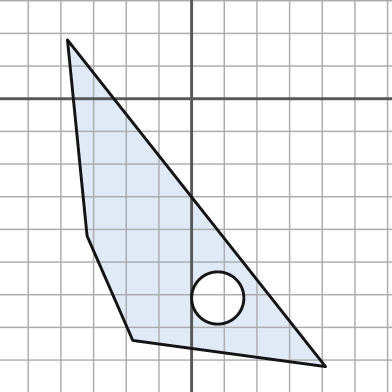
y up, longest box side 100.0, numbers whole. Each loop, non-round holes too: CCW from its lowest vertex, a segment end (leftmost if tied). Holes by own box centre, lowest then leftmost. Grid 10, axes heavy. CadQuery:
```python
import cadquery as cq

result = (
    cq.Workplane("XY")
    .moveTo(41.0, -82.0)
    .lineTo(-38.0, 18.0)
    .lineTo(-32.0, -42.0)
    .lineTo(-18.0, -74.0)
    .close()
    .moveTo(8.0, -61.0)
    .circle(8.0)
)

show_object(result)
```